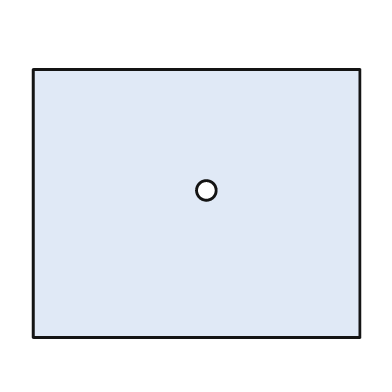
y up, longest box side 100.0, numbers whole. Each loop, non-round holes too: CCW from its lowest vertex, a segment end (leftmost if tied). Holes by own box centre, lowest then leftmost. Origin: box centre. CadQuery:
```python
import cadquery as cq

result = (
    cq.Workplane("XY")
    .moveTo(-50.0, -41.0)
    .lineTo(50.0, -41.0)
    .lineTo(50.0, 41.0)
    .lineTo(-50.0, 41.0)
    .close()
    .moveTo(3.0, 4.0)
    .circle(3.0)
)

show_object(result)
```